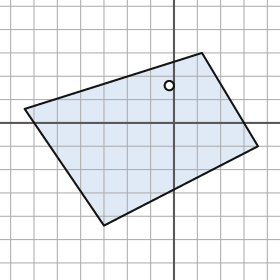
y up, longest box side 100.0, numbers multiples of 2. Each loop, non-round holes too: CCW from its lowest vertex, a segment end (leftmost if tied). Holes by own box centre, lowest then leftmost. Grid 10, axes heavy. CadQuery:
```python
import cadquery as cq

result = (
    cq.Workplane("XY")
    .moveTo(-30.0, -44.0)
    .lineTo(36.0, -10.0)
    .lineTo(12.0, 30.0)
    .lineTo(-64.0, 6.0)
    .close()
    .moveTo(-2.0, 16.0)
    .circle(2.0)
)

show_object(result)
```